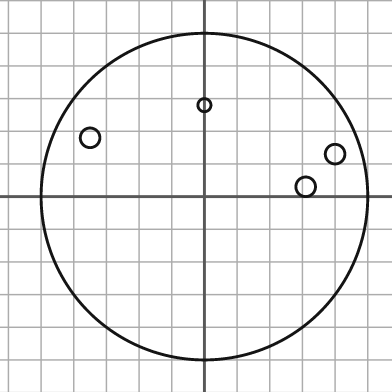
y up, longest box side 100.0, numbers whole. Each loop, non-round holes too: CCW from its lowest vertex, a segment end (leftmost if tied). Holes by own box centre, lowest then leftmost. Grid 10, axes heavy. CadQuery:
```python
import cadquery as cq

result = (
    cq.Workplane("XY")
    .moveTo(0.0, 0.0)
    .circle(50.0)
    .moveTo(31.0, 3.0)
    .circle(3.0)
    .moveTo(40.0, 13.0)
    .circle(3.0)
    .moveTo(-35.0, 18.0)
    .circle(3.0)
    .moveTo(0.0, 28.0)
    .circle(2.0)
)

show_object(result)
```